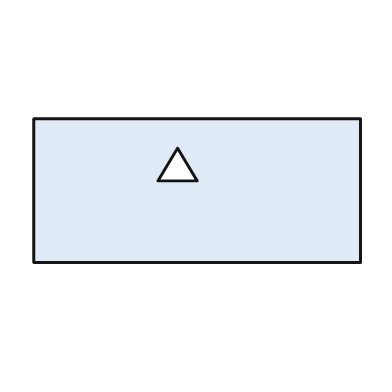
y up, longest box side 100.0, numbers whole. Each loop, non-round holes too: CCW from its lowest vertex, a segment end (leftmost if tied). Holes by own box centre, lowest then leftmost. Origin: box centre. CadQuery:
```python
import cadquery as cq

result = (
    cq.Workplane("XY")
    .moveTo(-50.0, -22.0)
    .lineTo(50.0, -22.0)
    .lineTo(50.0, 22.0)
    .lineTo(-50.0, 22.0)
    .close()
    .moveTo(-12.0, 3.0)
    .lineTo(0.0, 3.0)
    .lineTo(-6.0, 13.0)
    .close()
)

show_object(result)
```